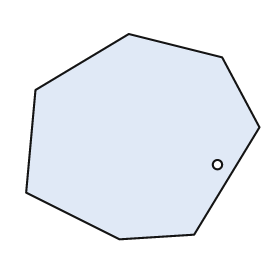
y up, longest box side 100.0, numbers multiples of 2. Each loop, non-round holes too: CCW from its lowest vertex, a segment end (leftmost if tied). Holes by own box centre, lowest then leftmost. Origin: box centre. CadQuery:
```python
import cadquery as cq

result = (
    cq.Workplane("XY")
    .moveTo(-10.0, -44.0)
    .lineTo(22.0, -42.0)
    .lineTo(50.0, 4.0)
    .lineTo(34.0, 34.0)
    .lineTo(-6.0, 44.0)
    .lineTo(-46.0, 20.0)
    .lineTo(-50.0, -24.0)
    .close()
    .moveTo(32.0, -12.0)
    .circle(2.0)
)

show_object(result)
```